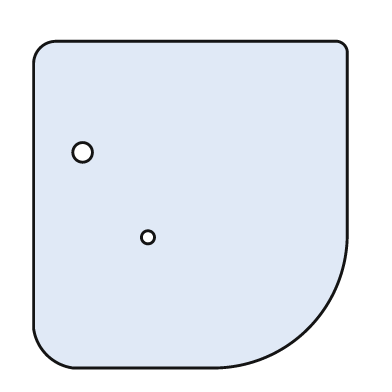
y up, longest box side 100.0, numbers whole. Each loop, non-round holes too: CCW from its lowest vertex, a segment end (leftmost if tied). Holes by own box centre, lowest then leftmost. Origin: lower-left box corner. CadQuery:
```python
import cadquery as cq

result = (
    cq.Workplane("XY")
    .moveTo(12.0, 0.0)
    .lineTo(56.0, 0.0)
    .threePointArc((84.0, 12.0), (96.0, 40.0))
    .lineTo(96.0, 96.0)
    .threePointArc((95.0, 99.0), (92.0, 100.0))
    .lineTo(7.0, 100.0)
    .threePointArc((2.0, 98.0), (0.0, 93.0))
    .lineTo(0.0, 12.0)
    .threePointArc((4.0, 4.0), (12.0, 0.0))
    .close()
    .moveTo(35.0, 40.0)
    .circle(2.0)
    .moveTo(15.0, 66.0)
    .circle(3.0)
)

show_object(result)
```